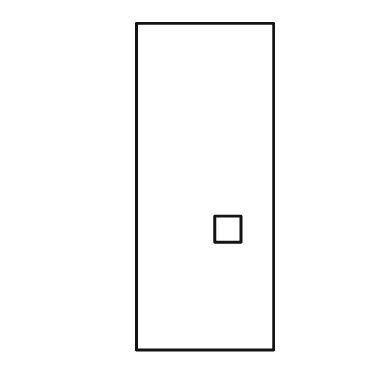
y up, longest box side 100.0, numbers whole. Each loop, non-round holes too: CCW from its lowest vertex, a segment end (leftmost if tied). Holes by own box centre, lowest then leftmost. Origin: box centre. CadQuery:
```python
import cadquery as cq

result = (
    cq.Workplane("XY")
    .moveTo(-21.0, -50.0)
    .lineTo(21.0, -50.0)
    .lineTo(21.0, 50.0)
    .lineTo(-21.0, 50.0)
    .close()
    .moveTo(3.0, -17.0)
    .lineTo(11.0, -17.0)
    .lineTo(11.0, -9.0)
    .lineTo(3.0, -9.0)
    .close()
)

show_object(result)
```